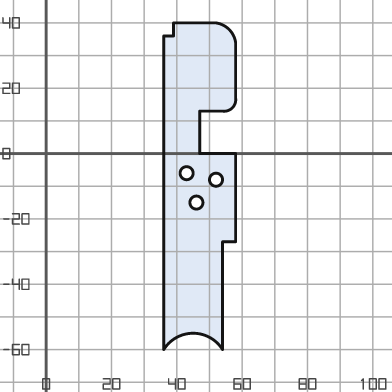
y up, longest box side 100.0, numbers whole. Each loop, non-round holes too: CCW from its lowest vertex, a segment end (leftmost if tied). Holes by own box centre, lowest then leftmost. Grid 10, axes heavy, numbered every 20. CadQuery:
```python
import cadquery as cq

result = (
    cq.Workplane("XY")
    .moveTo(36.0, -60.0)
    .threePointArc((45.0, -55.0), (54.0, -60.0))
    .lineTo(54.0, -27.0)
    .lineTo(58.0, -27.0)
    .lineTo(58.0, 0.0)
    .lineTo(47.0, 0.0)
    .lineTo(47.0, 13.0)
    .lineTo(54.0, 13.0)
    .threePointArc((57.0, 14.0), (58.0, 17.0))
    .lineTo(58.0, 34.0)
    .threePointArc((56.0, 38.0), (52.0, 40.0))
    .lineTo(39.0, 40.0)
    .lineTo(39.0, 36.0)
    .lineTo(36.0, 36.0)
    .close()
    .moveTo(46.0, -15.0)
    .circle(2.0)
    .moveTo(52.0, -8.0)
    .circle(2.0)
    .moveTo(43.0, -6.0)
    .circle(2.0)
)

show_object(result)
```